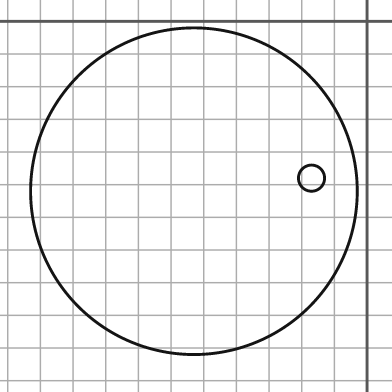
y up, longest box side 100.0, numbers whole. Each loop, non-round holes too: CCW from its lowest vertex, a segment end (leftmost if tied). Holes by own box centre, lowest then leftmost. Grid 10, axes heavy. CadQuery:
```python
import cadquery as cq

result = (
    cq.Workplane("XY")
    .moveTo(-53.0, -52.0)
    .circle(50.0)
    .moveTo(-17.0, -48.0)
    .circle(4.0)
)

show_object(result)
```